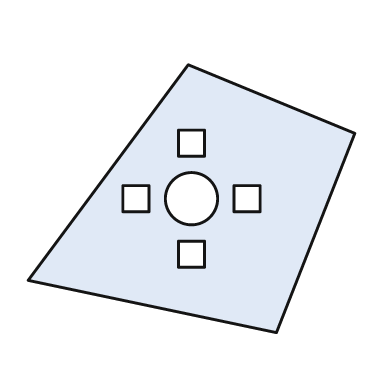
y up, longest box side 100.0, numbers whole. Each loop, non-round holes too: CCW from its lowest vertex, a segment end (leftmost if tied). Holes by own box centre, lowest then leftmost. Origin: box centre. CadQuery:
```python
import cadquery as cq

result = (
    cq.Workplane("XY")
    .moveTo(26.0, -41.0)
    .lineTo(50.0, 20.0)
    .lineTo(-1.0, 41.0)
    .lineTo(-50.0, -25.0)
    .close()
    .moveTo(-4.0, -21.0)
    .lineTo(4.0, -21.0)
    .lineTo(4.0, -13.0)
    .lineTo(-4.0, -13.0)
    .close()
    .moveTo(-21.0, -4.0)
    .lineTo(-13.0, -4.0)
    .lineTo(-13.0, 4.0)
    .lineTo(-21.0, 4.0)
    .close()
    .moveTo(0.0, 0.0)
    .circle(8.0)
    .moveTo(13.0, -4.0)
    .lineTo(21.0, -4.0)
    .lineTo(21.0, 4.0)
    .lineTo(13.0, 4.0)
    .close()
    .moveTo(-4.0, 13.0)
    .lineTo(4.0, 13.0)
    .lineTo(4.0, 21.0)
    .lineTo(-4.0, 21.0)
    .close()
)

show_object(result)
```